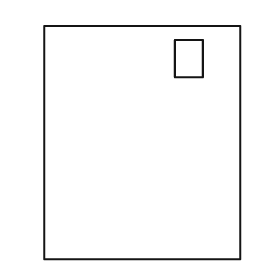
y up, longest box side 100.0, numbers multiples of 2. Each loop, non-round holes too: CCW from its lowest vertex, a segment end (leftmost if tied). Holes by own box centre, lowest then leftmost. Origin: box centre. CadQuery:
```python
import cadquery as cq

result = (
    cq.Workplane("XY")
    .moveTo(-42.0, -50.0)
    .lineTo(42.0, -50.0)
    .lineTo(42.0, 50.0)
    .lineTo(-42.0, 50.0)
    .close()
    .moveTo(14.0, 28.0)
    .lineTo(26.0, 28.0)
    .lineTo(26.0, 44.0)
    .lineTo(14.0, 44.0)
    .close()
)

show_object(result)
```